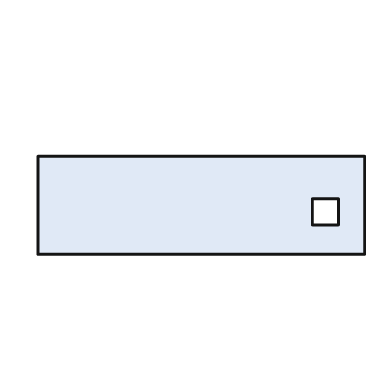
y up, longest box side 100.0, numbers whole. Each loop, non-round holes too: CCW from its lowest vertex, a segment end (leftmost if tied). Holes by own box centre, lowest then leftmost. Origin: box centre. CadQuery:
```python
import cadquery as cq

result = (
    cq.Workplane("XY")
    .moveTo(-50.0, -15.0)
    .lineTo(50.0, -15.0)
    .lineTo(50.0, 15.0)
    .lineTo(-50.0, 15.0)
    .close()
    .moveTo(34.0, -6.0)
    .lineTo(42.0, -6.0)
    .lineTo(42.0, 2.0)
    .lineTo(34.0, 2.0)
    .close()
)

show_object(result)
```